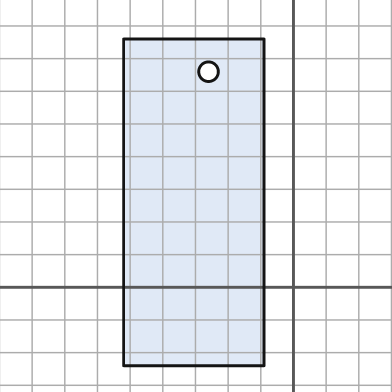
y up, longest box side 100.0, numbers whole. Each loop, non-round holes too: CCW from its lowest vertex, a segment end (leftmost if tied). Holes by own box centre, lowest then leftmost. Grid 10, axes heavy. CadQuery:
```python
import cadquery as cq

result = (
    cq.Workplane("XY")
    .moveTo(-52.0, -24.0)
    .lineTo(-9.0, -24.0)
    .lineTo(-9.0, 76.0)
    .lineTo(-52.0, 76.0)
    .close()
    .moveTo(-26.0, 66.0)
    .circle(3.0)
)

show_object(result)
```